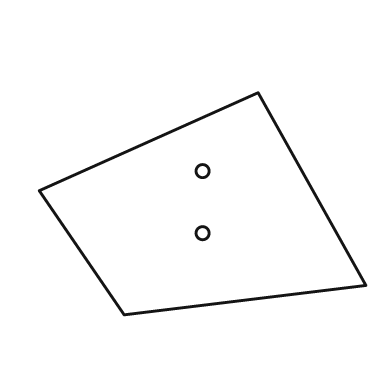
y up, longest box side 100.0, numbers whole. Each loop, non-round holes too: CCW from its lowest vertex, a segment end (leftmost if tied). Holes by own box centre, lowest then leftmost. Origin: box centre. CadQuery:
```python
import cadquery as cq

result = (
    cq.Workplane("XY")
    .moveTo(-24.0, -34.0)
    .lineTo(50.0, -25.0)
    .lineTo(17.0, 34.0)
    .lineTo(-50.0, 4.0)
    .close()
    .moveTo(0.0, -9.0)
    .circle(2.0)
    .moveTo(0.0, 10.0)
    .circle(2.0)
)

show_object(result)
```